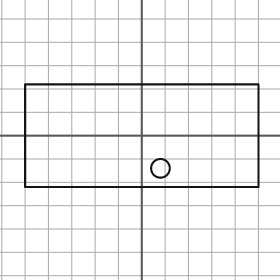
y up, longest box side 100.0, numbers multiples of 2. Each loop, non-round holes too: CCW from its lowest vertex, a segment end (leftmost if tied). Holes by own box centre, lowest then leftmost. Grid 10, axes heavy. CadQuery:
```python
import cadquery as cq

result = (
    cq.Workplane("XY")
    .moveTo(-50.0, -22.0)
    .lineTo(50.0, -22.0)
    .lineTo(50.0, 22.0)
    .lineTo(-50.0, 22.0)
    .close()
    .moveTo(8.0, -14.0)
    .circle(4.0)
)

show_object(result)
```